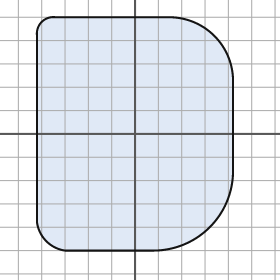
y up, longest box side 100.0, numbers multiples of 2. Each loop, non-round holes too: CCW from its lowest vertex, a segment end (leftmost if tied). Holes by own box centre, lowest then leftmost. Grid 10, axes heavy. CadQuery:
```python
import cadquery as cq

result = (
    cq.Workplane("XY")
    .moveTo(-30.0, -50.0)
    .lineTo(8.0, -50.0)
    .threePointArc((32.0, -40.0), (42.0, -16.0))
    .lineTo(42.0, 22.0)
    .threePointArc((34.0, 42.0), (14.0, 50.0))
    .lineTo(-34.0, 50.0)
    .threePointArc((-40.0, 48.0), (-42.0, 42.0))
    .lineTo(-42.0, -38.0)
    .threePointArc((-38.0, -46.0), (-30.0, -50.0))
    .close()
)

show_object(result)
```